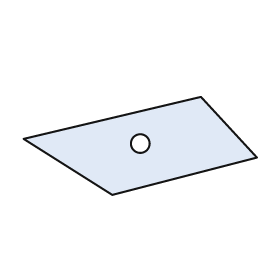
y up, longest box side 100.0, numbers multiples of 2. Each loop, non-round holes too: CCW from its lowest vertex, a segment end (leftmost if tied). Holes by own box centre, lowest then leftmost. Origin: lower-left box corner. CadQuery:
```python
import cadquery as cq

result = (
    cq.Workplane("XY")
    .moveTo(38.0, 0.0)
    .lineTo(100.0, 16.0)
    .lineTo(76.0, 42.0)
    .lineTo(0.0, 24.0)
    .close()
    .moveTo(50.0, 22.0)
    .circle(4.0)
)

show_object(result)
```